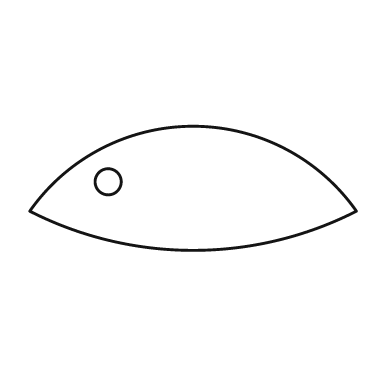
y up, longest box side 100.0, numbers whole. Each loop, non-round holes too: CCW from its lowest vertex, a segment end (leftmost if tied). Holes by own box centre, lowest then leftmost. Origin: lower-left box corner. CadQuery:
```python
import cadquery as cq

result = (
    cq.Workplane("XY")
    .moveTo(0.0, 12.0)
    .threePointArc((50.0, 0.0), (100.0, 12.0))
    .threePointArc((50.0, 38.0), (0.0, 12.0))
    .close()
    .moveTo(24.0, 21.0)
    .circle(4.0)
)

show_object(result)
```